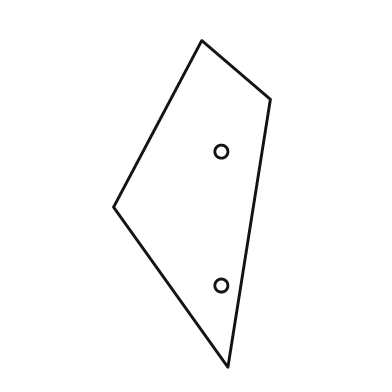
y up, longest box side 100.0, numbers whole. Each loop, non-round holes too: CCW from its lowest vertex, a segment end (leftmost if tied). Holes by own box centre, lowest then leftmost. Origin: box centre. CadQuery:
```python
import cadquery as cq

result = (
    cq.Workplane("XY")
    .moveTo(11.0, -50.0)
    .lineTo(24.0, 32.0)
    .lineTo(3.0, 50.0)
    .lineTo(-24.0, -1.0)
    .close()
    .moveTo(9.0, -25.0)
    .circle(2.0)
    .moveTo(9.0, 16.0)
    .circle(2.0)
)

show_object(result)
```